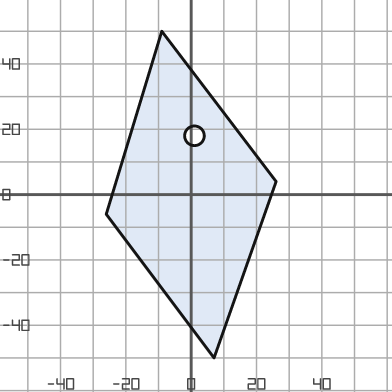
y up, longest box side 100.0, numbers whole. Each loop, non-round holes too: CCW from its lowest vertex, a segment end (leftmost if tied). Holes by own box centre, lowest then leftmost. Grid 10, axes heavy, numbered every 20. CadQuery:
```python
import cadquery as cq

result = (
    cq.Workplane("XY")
    .moveTo(7.0, -50.0)
    .lineTo(26.0, 4.0)
    .lineTo(-9.0, 50.0)
    .lineTo(-26.0, -6.0)
    .close()
    .moveTo(1.0, 18.0)
    .circle(3.0)
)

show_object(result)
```